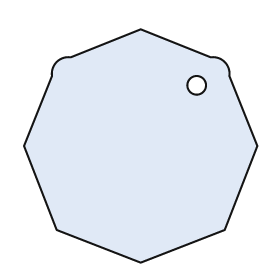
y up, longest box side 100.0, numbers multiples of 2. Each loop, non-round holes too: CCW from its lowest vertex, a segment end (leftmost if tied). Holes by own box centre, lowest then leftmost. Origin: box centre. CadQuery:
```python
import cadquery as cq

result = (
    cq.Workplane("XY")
    .moveTo(0.0, -50.0)
    .lineTo(36.0, -36.0)
    .lineTo(50.0, 0.0)
    .lineTo(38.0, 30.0)
    .threePointArc((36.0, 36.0), (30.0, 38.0))
    .lineTo(0.0, 50.0)
    .lineTo(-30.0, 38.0)
    .threePointArc((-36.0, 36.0), (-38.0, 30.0))
    .lineTo(-50.0, 0.0)
    .lineTo(-36.0, -36.0)
    .close()
    .moveTo(24.0, 26.0)
    .circle(4.0)
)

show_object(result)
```